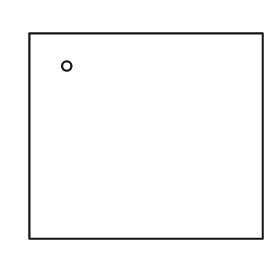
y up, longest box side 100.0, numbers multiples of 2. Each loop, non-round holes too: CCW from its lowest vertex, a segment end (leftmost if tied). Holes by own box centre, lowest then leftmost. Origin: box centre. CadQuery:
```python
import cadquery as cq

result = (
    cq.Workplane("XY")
    .moveTo(-50.0, -44.0)
    .lineTo(50.0, -44.0)
    .lineTo(50.0, 44.0)
    .lineTo(-50.0, 44.0)
    .close()
    .moveTo(-34.0, 30.0)
    .circle(2.0)
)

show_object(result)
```